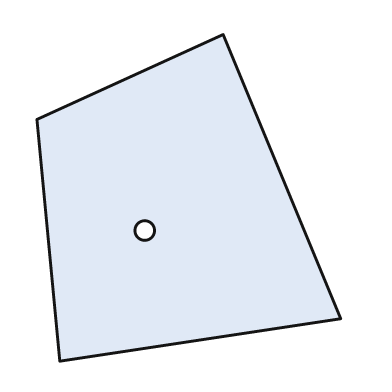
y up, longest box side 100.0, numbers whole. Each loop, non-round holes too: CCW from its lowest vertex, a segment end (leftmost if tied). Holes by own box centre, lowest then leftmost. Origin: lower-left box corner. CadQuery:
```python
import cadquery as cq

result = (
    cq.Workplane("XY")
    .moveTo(7.0, 0.0)
    .lineTo(93.0, 13.0)
    .lineTo(57.0, 100.0)
    .lineTo(0.0, 74.0)
    .close()
    .moveTo(33.0, 40.0)
    .circle(3.0)
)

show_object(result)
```